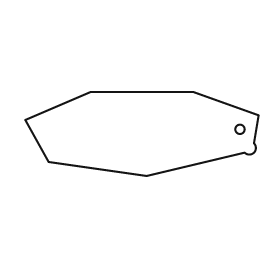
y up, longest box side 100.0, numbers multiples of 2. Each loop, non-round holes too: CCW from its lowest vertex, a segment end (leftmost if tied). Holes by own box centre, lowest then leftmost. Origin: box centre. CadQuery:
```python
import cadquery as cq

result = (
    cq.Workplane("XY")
    .moveTo(2.0, -18.0)
    .lineTo(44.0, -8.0)
    .threePointArc((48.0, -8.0), (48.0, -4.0))
    .lineTo(50.0, 8.0)
    .lineTo(22.0, 18.0)
    .lineTo(-22.0, 18.0)
    .lineTo(-50.0, 6.0)
    .lineTo(-40.0, -12.0)
    .close()
    .moveTo(42.0, 2.0)
    .circle(2.0)
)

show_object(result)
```